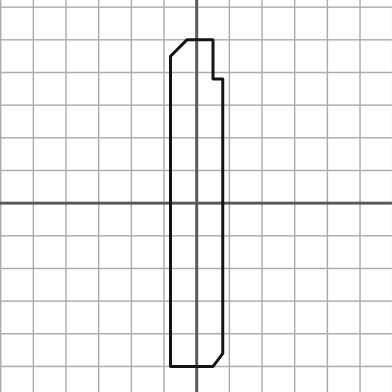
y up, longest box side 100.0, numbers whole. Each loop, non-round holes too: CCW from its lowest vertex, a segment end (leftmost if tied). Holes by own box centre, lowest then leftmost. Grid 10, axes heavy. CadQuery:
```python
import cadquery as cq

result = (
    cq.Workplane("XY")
    .moveTo(-8.0, -50.0)
    .lineTo(5.0, -50.0)
    .lineTo(8.0, -46.0)
    .lineTo(8.0, 38.0)
    .lineTo(5.0, 38.0)
    .lineTo(5.0, 50.0)
    .lineTo(-3.0, 50.0)
    .lineTo(-8.0, 45.0)
    .close()
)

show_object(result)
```